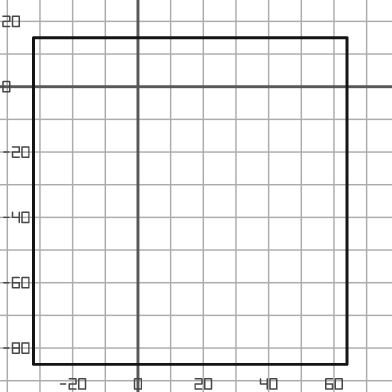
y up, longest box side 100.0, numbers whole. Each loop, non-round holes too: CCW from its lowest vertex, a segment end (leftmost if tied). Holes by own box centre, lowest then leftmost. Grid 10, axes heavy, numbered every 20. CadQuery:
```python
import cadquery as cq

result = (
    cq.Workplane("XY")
    .moveTo(-32.0, -85.0)
    .lineTo(64.0, -85.0)
    .lineTo(64.0, 15.0)
    .lineTo(-32.0, 15.0)
    .close()
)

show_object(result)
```